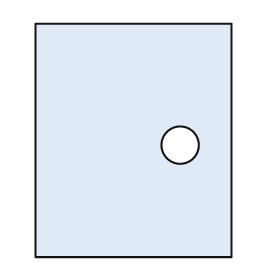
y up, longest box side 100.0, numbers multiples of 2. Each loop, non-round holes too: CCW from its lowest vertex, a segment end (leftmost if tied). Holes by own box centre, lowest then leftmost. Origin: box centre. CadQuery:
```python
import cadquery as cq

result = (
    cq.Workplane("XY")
    .moveTo(-42.0, -50.0)
    .lineTo(42.0, -50.0)
    .lineTo(42.0, 50.0)
    .lineTo(-42.0, 50.0)
    .close()
    .moveTo(20.0, -2.0)
    .circle(8.0)
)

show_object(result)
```